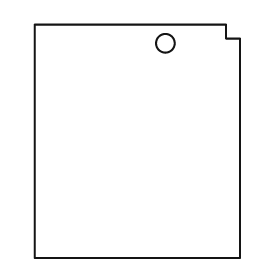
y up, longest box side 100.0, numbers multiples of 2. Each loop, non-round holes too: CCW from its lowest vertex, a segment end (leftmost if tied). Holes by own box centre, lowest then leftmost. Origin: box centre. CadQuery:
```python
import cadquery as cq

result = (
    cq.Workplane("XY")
    .moveTo(-44.0, -50.0)
    .lineTo(44.0, -50.0)
    .lineTo(44.0, 44.0)
    .lineTo(38.0, 44.0)
    .lineTo(38.0, 50.0)
    .lineTo(-44.0, 50.0)
    .close()
    .moveTo(12.0, 42.0)
    .circle(4.0)
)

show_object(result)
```